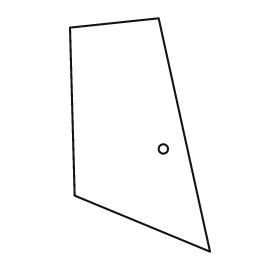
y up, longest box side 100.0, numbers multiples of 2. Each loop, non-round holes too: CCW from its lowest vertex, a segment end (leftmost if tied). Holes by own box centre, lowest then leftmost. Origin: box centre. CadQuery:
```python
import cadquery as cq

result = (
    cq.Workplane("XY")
    .moveTo(30.0, -50.0)
    .lineTo(8.0, 50.0)
    .lineTo(-30.0, 46.0)
    .lineTo(-28.0, -26.0)
    .close()
    .moveTo(10.0, -6.0)
    .circle(2.0)
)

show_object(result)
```